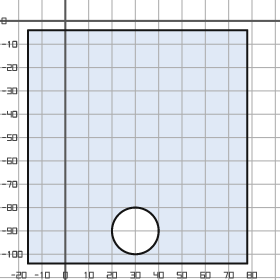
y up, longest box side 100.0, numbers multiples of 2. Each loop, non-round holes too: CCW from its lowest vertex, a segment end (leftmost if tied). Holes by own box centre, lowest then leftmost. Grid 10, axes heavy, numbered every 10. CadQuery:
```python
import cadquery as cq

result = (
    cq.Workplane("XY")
    .moveTo(-16.0, -104.0)
    .lineTo(78.0, -104.0)
    .lineTo(78.0, -4.0)
    .lineTo(-16.0, -4.0)
    .close()
    .moveTo(30.0, -90.0)
    .circle(10.0)
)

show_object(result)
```